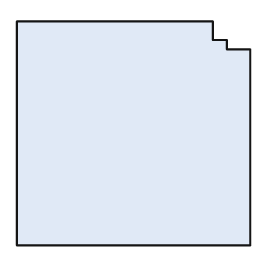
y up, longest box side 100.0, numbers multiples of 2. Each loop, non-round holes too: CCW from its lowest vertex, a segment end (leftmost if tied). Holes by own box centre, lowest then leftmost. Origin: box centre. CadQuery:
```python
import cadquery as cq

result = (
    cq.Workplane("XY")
    .moveTo(-50.0, -48.0)
    .lineTo(50.0, -48.0)
    .lineTo(50.0, 36.0)
    .lineTo(40.0, 36.0)
    .lineTo(40.0, 40.0)
    .lineTo(34.0, 40.0)
    .lineTo(34.0, 48.0)
    .lineTo(-50.0, 48.0)
    .close()
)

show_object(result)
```